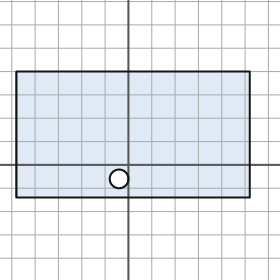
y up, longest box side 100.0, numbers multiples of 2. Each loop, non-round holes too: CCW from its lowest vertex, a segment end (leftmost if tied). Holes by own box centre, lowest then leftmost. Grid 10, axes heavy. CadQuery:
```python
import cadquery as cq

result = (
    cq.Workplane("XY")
    .moveTo(-48.0, -14.0)
    .lineTo(52.0, -14.0)
    .lineTo(52.0, 40.0)
    .lineTo(-48.0, 40.0)
    .close()
    .moveTo(-4.0, -6.0)
    .circle(4.0)
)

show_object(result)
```